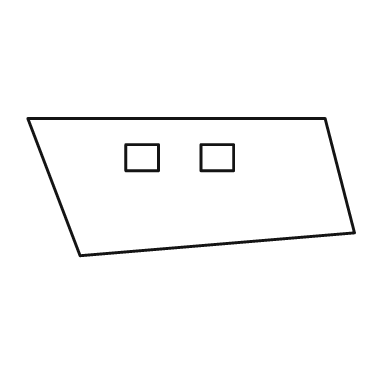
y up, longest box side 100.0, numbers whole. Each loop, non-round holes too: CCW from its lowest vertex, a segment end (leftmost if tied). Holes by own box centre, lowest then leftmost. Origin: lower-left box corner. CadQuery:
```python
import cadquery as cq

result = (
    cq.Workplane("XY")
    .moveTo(16.0, 0.0)
    .lineTo(100.0, 7.0)
    .lineTo(91.0, 42.0)
    .lineTo(0.0, 42.0)
    .close()
    .moveTo(30.0, 26.0)
    .lineTo(40.0, 26.0)
    .lineTo(40.0, 34.0)
    .lineTo(30.0, 34.0)
    .close()
    .moveTo(53.0, 26.0)
    .lineTo(63.0, 26.0)
    .lineTo(63.0, 34.0)
    .lineTo(53.0, 34.0)
    .close()
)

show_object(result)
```